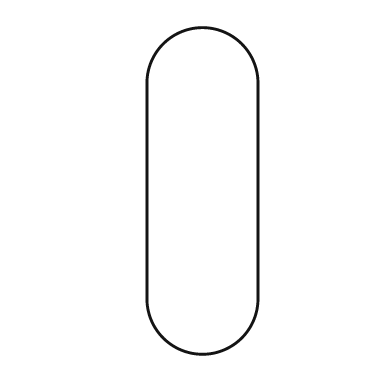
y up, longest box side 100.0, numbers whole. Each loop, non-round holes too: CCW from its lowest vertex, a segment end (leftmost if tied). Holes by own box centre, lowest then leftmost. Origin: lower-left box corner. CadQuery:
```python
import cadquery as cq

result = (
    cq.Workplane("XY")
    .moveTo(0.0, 17.0)
    .threePointArc((17.0, 0.0), (34.0, 17.0))
    .lineTo(34.0, 83.0)
    .threePointArc((17.0, 100.0), (0.0, 83.0))
    .close()
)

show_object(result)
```